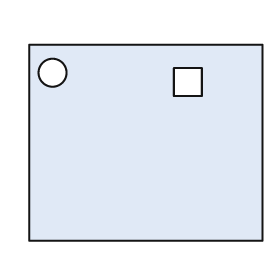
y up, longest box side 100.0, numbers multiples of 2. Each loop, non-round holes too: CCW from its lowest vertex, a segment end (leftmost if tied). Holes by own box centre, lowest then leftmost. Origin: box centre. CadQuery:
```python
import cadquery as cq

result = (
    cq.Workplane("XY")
    .moveTo(-50.0, -42.0)
    .lineTo(50.0, -42.0)
    .lineTo(50.0, 42.0)
    .lineTo(-50.0, 42.0)
    .close()
    .moveTo(12.0, 20.0)
    .lineTo(24.0, 20.0)
    .lineTo(24.0, 32.0)
    .lineTo(12.0, 32.0)
    .close()
    .moveTo(-40.0, 30.0)
    .circle(6.0)
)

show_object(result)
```